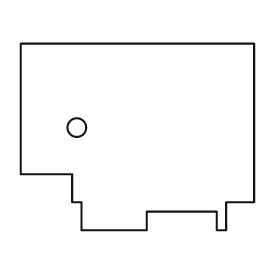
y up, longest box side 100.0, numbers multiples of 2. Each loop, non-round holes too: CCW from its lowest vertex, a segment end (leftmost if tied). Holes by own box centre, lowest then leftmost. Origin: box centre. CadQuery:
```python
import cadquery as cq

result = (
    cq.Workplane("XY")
    .moveTo(-24.0, -40.0)
    .lineTo(4.0, -40.0)
    .lineTo(4.0, -32.0)
    .lineTo(34.0, -32.0)
    .lineTo(34.0, -40.0)
    .lineTo(38.0, -40.0)
    .lineTo(38.0, -28.0)
    .lineTo(50.0, -28.0)
    .lineTo(50.0, 40.0)
    .lineTo(-50.0, 40.0)
    .lineTo(-50.0, -16.0)
    .lineTo(-28.0, -16.0)
    .lineTo(-28.0, -28.0)
    .lineTo(-24.0, -28.0)
    .close()
    .moveTo(-26.0, 4.0)
    .circle(4.0)
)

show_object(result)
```